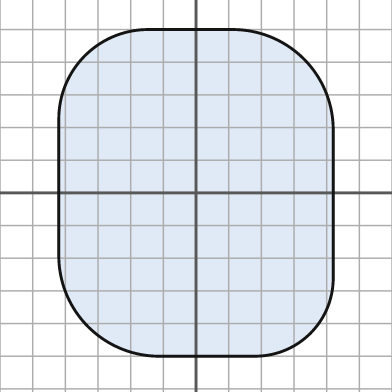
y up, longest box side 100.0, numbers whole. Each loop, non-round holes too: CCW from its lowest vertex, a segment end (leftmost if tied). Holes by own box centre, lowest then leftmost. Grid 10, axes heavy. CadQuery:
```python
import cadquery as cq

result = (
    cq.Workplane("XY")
    .moveTo(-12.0, -50.0)
    .lineTo(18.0, -50.0)
    .threePointArc((35.0, -43.0), (42.0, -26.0))
    .lineTo(42.0, 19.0)
    .threePointArc((33.0, 41.0), (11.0, 50.0))
    .lineTo(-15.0, 50.0)
    .threePointArc((-34.0, 42.0), (-42.0, 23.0))
    .lineTo(-42.0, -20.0)
    .threePointArc((-33.0, -41.0), (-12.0, -50.0))
    .close()
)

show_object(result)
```